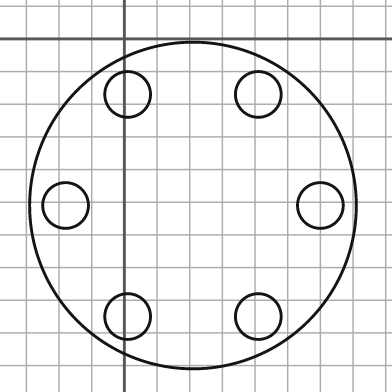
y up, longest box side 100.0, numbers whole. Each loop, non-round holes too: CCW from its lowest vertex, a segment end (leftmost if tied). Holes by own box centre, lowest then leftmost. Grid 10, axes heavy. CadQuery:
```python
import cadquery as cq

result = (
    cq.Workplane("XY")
    .moveTo(21.0, -51.0)
    .circle(50.0)
    .moveTo(1.0, -85.0)
    .circle(7.0)
    .moveTo(41.0, -85.0)
    .circle(7.0)
    .moveTo(-18.0, -51.0)
    .circle(7.0)
    .moveTo(60.0, -51.0)
    .circle(7.0)
    .moveTo(1.0, -17.0)
    .circle(7.0)
    .moveTo(41.0, -17.0)
    .circle(7.0)
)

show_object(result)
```